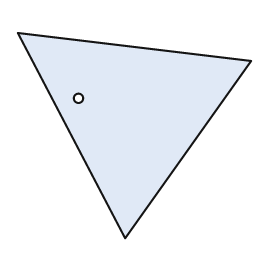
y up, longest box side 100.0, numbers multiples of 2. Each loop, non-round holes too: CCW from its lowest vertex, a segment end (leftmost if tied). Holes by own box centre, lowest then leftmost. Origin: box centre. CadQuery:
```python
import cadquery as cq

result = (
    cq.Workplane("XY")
    .moveTo(-4.0, -44.0)
    .lineTo(50.0, 32.0)
    .lineTo(-50.0, 44.0)
    .close()
    .moveTo(-24.0, 16.0)
    .circle(2.0)
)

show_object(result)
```